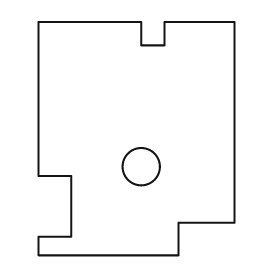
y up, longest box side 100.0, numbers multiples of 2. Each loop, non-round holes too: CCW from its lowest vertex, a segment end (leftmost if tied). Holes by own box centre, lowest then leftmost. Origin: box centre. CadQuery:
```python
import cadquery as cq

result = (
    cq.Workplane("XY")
    .moveTo(-42.0, -50.0)
    .lineTo(18.0, -50.0)
    .lineTo(18.0, -36.0)
    .lineTo(42.0, -36.0)
    .lineTo(42.0, 50.0)
    .lineTo(12.0, 50.0)
    .lineTo(12.0, 40.0)
    .lineTo(2.0, 40.0)
    .lineTo(2.0, 50.0)
    .lineTo(-42.0, 50.0)
    .lineTo(-42.0, -16.0)
    .lineTo(-28.0, -16.0)
    .lineTo(-28.0, -42.0)
    .lineTo(-42.0, -42.0)
    .close()
    .moveTo(2.0, -12.0)
    .circle(8.0)
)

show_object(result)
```